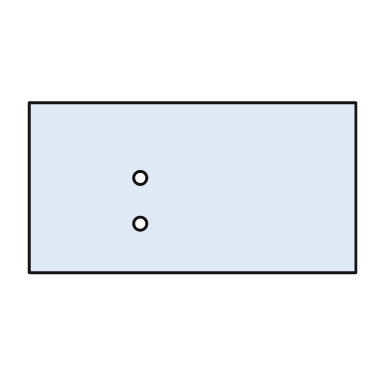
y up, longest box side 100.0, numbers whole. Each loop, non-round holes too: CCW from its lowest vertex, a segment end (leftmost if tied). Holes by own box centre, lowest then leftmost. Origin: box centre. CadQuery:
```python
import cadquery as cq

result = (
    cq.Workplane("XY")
    .moveTo(-50.0, -26.0)
    .lineTo(50.0, -26.0)
    .lineTo(50.0, 26.0)
    .lineTo(-50.0, 26.0)
    .close()
    .moveTo(-16.0, -11.0)
    .circle(2.0)
    .moveTo(-16.0, 3.0)
    .circle(2.0)
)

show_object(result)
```